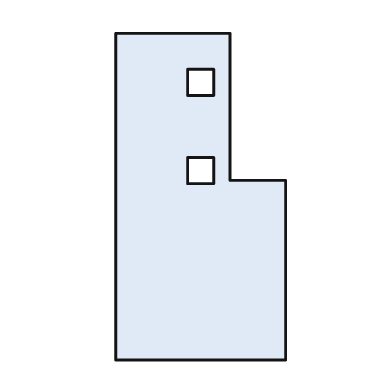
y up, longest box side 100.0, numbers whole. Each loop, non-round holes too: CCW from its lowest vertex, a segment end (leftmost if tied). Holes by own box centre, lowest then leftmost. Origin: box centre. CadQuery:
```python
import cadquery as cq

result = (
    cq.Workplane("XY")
    .moveTo(-26.0, -50.0)
    .lineTo(26.0, -50.0)
    .lineTo(26.0, 5.0)
    .lineTo(9.0, 5.0)
    .lineTo(9.0, 50.0)
    .lineTo(-26.0, 50.0)
    .close()
    .moveTo(-4.0, 4.0)
    .lineTo(4.0, 4.0)
    .lineTo(4.0, 12.0)
    .lineTo(-4.0, 12.0)
    .close()
    .moveTo(-4.0, 31.0)
    .lineTo(4.0, 31.0)
    .lineTo(4.0, 39.0)
    .lineTo(-4.0, 39.0)
    .close()
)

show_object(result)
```